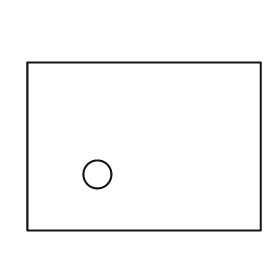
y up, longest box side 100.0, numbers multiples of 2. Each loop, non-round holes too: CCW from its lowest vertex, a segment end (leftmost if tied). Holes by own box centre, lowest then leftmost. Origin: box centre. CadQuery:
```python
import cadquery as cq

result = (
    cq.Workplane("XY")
    .moveTo(-50.0, -36.0)
    .lineTo(50.0, -36.0)
    .lineTo(50.0, 36.0)
    .lineTo(-50.0, 36.0)
    .close()
    .moveTo(-20.0, -12.0)
    .circle(6.0)
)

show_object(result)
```